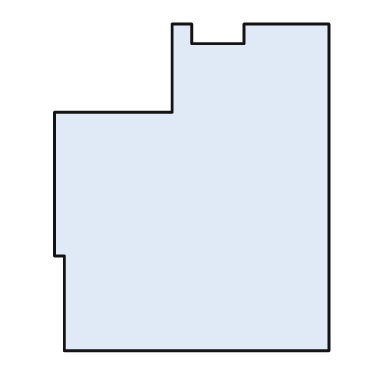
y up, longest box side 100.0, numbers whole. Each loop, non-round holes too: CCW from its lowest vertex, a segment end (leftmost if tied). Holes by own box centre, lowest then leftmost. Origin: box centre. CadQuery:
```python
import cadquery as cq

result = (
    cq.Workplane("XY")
    .moveTo(-39.0, -50.0)
    .lineTo(42.0, -50.0)
    .lineTo(42.0, 50.0)
    .lineTo(16.0, 50.0)
    .lineTo(16.0, 44.0)
    .lineTo(0.0, 44.0)
    .lineTo(0.0, 50.0)
    .lineTo(-6.0, 50.0)
    .lineTo(-6.0, 23.0)
    .lineTo(-42.0, 23.0)
    .lineTo(-42.0, -21.0)
    .lineTo(-39.0, -21.0)
    .close()
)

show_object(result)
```